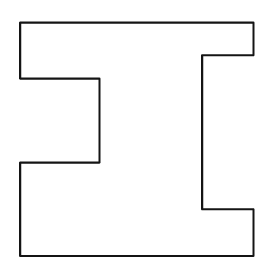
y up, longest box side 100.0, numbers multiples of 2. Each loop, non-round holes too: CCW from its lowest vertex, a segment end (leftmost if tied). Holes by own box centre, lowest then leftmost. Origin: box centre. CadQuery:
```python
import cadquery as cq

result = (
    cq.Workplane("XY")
    .moveTo(-50.0, -50.0)
    .lineTo(50.0, -50.0)
    .lineTo(50.0, -30.0)
    .lineTo(28.0, -30.0)
    .lineTo(28.0, 36.0)
    .lineTo(50.0, 36.0)
    .lineTo(50.0, 50.0)
    .lineTo(-50.0, 50.0)
    .lineTo(-50.0, 26.0)
    .lineTo(-16.0, 26.0)
    .lineTo(-16.0, -10.0)
    .lineTo(-50.0, -10.0)
    .close()
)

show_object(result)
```